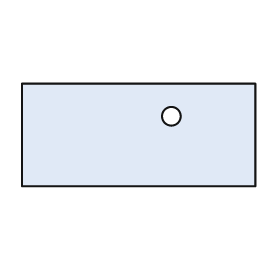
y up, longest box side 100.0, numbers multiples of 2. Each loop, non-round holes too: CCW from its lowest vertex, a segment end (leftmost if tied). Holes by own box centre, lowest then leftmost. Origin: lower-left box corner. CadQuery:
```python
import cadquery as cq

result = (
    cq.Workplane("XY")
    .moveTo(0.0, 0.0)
    .lineTo(100.0, 0.0)
    .lineTo(100.0, 44.0)
    .lineTo(0.0, 44.0)
    .close()
    .moveTo(64.0, 30.0)
    .circle(4.0)
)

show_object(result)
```